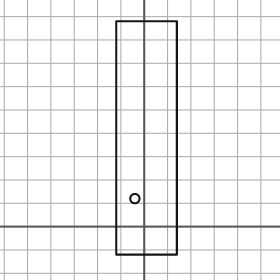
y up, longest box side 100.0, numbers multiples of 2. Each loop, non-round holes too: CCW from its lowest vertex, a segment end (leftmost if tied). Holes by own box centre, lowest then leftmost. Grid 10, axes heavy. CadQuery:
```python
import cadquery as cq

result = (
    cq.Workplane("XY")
    .moveTo(-12.0, -12.0)
    .lineTo(14.0, -12.0)
    .lineTo(14.0, 88.0)
    .lineTo(-12.0, 88.0)
    .close()
    .moveTo(-4.0, 12.0)
    .circle(2.0)
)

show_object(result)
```